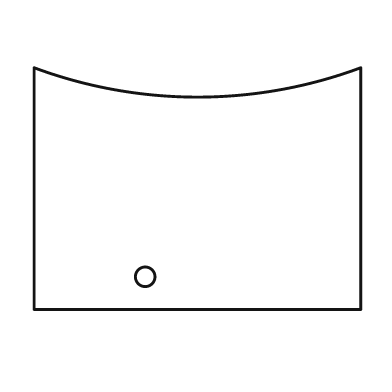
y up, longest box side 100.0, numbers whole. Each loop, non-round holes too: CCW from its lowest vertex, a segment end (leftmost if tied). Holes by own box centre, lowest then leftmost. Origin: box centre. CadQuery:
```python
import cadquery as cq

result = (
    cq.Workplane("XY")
    .moveTo(-50.0, -37.0)
    .lineTo(50.0, -37.0)
    .lineTo(50.0, 37.0)
    .threePointArc((0.0, 28.0), (-50.0, 37.0))
    .close()
    .moveTo(-16.0, -27.0)
    .circle(3.0)
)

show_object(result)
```